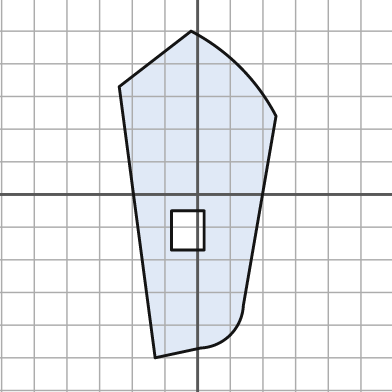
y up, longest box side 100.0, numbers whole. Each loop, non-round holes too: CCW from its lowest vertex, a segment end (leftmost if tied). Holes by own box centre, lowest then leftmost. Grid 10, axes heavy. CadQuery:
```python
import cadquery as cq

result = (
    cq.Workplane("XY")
    .moveTo(-13.0, -50.0)
    .lineTo(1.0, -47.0)
    .threePointArc((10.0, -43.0), (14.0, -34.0))
    .lineTo(24.0, 24.0)
    .threePointArc((13.0, 39.0), (-2.0, 50.0))
    .lineTo(-24.0, 33.0)
    .close()
    .moveTo(-8.0, -17.0)
    .lineTo(2.0, -17.0)
    .lineTo(2.0, -5.0)
    .lineTo(-8.0, -5.0)
    .close()
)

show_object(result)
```